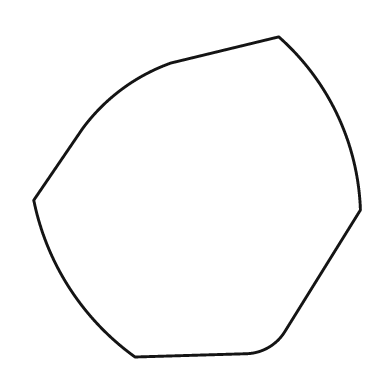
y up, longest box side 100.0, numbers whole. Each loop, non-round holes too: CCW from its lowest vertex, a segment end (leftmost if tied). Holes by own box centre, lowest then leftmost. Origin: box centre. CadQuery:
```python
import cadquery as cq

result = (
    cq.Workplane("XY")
    .moveTo(-19.0, -49.0)
    .lineTo(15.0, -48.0)
    .threePointArc((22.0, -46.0), (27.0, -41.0))
    .lineTo(50.0, -4.0)
    .threePointArc((43.0, 25.0), (25.0, 49.0))
    .lineTo(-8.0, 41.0)
    .threePointArc((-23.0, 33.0), (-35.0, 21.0))
    .lineTo(-50.0, -1.0)
    .threePointArc((-39.0, -28.0), (-19.0, -49.0))
    .close()
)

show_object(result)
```